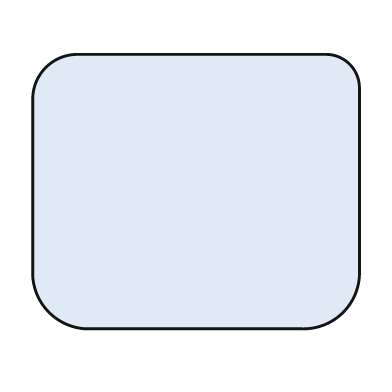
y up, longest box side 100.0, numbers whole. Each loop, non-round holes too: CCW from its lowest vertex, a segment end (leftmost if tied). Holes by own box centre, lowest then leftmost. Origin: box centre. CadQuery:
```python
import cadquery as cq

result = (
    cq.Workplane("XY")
    .moveTo(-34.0, -42.0)
    .lineTo(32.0, -42.0)
    .threePointArc((45.0, -37.0), (50.0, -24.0))
    .lineTo(50.0, 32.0)
    .threePointArc((47.0, 39.0), (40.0, 42.0))
    .lineTo(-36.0, 42.0)
    .threePointArc((-46.0, 38.0), (-50.0, 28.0))
    .lineTo(-50.0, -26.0)
    .threePointArc((-45.0, -37.0), (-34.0, -42.0))
    .close()
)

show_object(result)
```